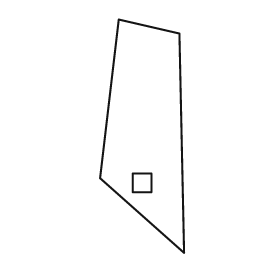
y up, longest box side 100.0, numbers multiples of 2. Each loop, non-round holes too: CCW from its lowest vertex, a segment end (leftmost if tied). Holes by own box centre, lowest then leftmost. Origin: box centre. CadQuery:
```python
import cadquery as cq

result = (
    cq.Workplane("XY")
    .moveTo(18.0, -50.0)
    .lineTo(16.0, 44.0)
    .lineTo(-10.0, 50.0)
    .lineTo(-18.0, -18.0)
    .close()
    .moveTo(-4.0, -24.0)
    .lineTo(4.0, -24.0)
    .lineTo(4.0, -16.0)
    .lineTo(-4.0, -16.0)
    .close()
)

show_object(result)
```